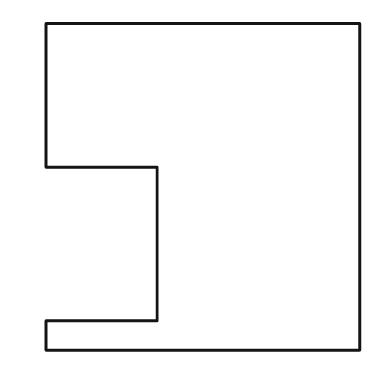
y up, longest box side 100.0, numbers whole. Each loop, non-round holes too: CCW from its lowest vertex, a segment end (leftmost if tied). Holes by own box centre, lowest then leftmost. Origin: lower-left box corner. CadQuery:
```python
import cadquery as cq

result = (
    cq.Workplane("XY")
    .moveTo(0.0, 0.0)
    .lineTo(96.0, 0.0)
    .lineTo(96.0, 100.0)
    .lineTo(0.0, 100.0)
    .lineTo(0.0, 56.0)
    .lineTo(34.0, 56.0)
    .lineTo(34.0, 9.0)
    .lineTo(0.0, 9.0)
    .close()
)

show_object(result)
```